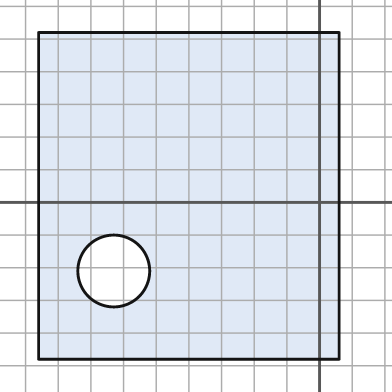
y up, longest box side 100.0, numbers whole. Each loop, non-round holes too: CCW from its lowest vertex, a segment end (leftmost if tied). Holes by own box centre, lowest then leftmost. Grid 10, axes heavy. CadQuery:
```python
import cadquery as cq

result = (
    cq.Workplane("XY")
    .moveTo(-86.0, -48.0)
    .lineTo(6.0, -48.0)
    .lineTo(6.0, 52.0)
    .lineTo(-86.0, 52.0)
    .close()
    .moveTo(-63.0, -21.0)
    .circle(11.0)
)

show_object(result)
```